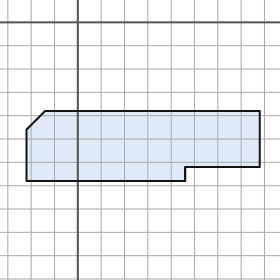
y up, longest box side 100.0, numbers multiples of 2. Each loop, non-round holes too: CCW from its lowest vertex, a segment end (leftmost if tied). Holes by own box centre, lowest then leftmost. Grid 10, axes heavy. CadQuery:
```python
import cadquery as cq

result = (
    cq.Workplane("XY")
    .moveTo(-22.0, -68.0)
    .lineTo(46.0, -68.0)
    .lineTo(46.0, -62.0)
    .lineTo(78.0, -62.0)
    .lineTo(78.0, -38.0)
    .lineTo(-14.0, -38.0)
    .lineTo(-22.0, -46.0)
    .close()
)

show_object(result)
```